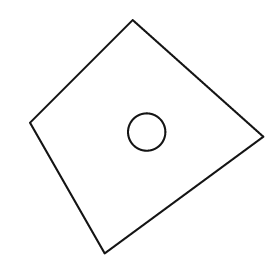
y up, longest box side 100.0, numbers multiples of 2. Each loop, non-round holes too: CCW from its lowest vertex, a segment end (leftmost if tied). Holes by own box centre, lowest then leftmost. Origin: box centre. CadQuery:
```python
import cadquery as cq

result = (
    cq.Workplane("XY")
    .moveTo(-18.0, -50.0)
    .lineTo(50.0, 0.0)
    .lineTo(-6.0, 50.0)
    .lineTo(-50.0, 6.0)
    .close()
    .moveTo(0.0, 2.0)
    .circle(8.0)
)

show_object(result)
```